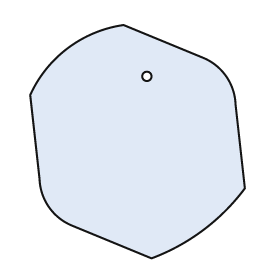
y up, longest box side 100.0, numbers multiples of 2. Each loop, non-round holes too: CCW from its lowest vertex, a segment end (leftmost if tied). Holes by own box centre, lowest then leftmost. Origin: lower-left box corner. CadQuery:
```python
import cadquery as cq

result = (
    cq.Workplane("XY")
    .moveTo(52.0, 0.0)
    .threePointArc((74.0, 12.0), (92.0, 30.0))
    .lineTo(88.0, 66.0)
    .threePointArc((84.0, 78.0), (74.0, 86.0))
    .lineTo(40.0, 100.0)
    .threePointArc((16.0, 90.0), (0.0, 70.0))
    .lineTo(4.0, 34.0)
    .threePointArc((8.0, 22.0), (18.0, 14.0))
    .close()
    .moveTo(50.0, 78.0)
    .circle(2.0)
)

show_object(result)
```